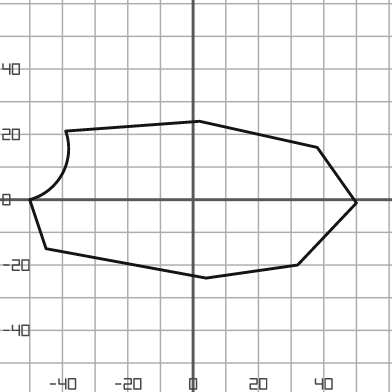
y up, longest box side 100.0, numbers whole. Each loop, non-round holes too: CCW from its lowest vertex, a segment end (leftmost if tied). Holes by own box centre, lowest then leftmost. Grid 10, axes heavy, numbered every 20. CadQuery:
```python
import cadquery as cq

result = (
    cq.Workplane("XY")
    .moveTo(4.0, -24.0)
    .lineTo(32.0, -20.0)
    .lineTo(50.0, -1.0)
    .lineTo(38.0, 16.0)
    .lineTo(2.0, 24.0)
    .lineTo(-39.0, 21.0)
    .threePointArc((-40.0, 8.0), (-50.0, 0.0))
    .lineTo(-45.0, -15.0)
    .close()
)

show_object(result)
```